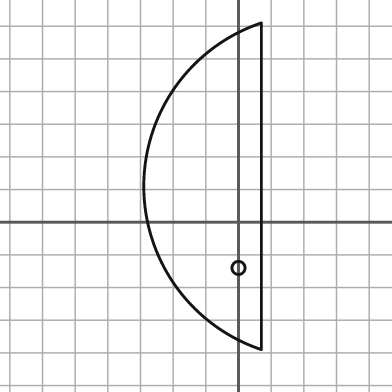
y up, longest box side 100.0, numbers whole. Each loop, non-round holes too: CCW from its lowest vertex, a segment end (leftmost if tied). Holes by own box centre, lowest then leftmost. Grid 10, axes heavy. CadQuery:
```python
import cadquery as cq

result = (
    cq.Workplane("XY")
    .moveTo(7.0, -39.0)
    .lineTo(7.0, 61.0)
    .threePointArc((-29.0, 11.0), (7.0, -39.0))
    .close()
    .moveTo(0.0, -14.0)
    .circle(2.0)
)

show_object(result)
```